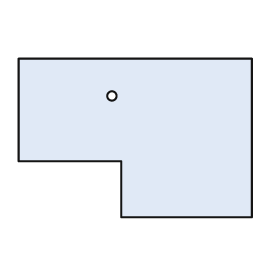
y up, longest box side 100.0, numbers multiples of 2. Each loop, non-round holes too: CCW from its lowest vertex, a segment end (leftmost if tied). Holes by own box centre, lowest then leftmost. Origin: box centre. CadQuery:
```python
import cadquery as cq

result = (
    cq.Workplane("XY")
    .moveTo(-6.0, -34.0)
    .lineTo(50.0, -34.0)
    .lineTo(50.0, 34.0)
    .lineTo(-50.0, 34.0)
    .lineTo(-50.0, -10.0)
    .lineTo(-6.0, -10.0)
    .close()
    .moveTo(-10.0, 18.0)
    .circle(2.0)
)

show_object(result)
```